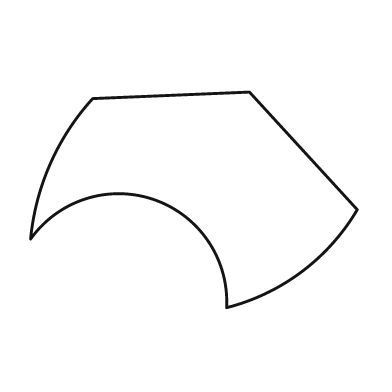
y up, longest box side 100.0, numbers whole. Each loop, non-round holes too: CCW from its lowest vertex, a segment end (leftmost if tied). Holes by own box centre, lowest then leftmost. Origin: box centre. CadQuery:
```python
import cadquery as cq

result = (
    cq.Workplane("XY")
    .moveTo(10.0, -33.0)
    .threePointArc((33.0, -22.0), (50.0, -3.0))
    .lineTo(17.0, 33.0)
    .lineTo(-31.0, 31.0)
    .threePointArc((-44.0, 11.0), (-50.0, -12.0))
    .threePointArc((-12.0, 0.0), (10.0, -33.0))
    .close()
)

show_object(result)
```